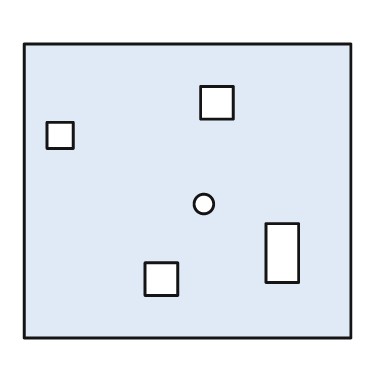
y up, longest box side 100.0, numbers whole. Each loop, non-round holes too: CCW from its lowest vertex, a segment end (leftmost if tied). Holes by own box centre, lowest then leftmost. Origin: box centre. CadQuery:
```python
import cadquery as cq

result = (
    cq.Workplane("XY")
    .moveTo(-50.0, -45.0)
    .lineTo(50.0, -45.0)
    .lineTo(50.0, 45.0)
    .lineTo(-50.0, 45.0)
    .close()
    .moveTo(-13.0, -32.0)
    .lineTo(-3.0, -32.0)
    .lineTo(-3.0, -22.0)
    .lineTo(-13.0, -22.0)
    .close()
    .moveTo(24.0, -28.0)
    .lineTo(34.0, -28.0)
    .lineTo(34.0, -10.0)
    .lineTo(24.0, -10.0)
    .close()
    .moveTo(5.0, -4.0)
    .circle(3.0)
    .moveTo(-43.0, 13.0)
    .lineTo(-35.0, 13.0)
    .lineTo(-35.0, 21.0)
    .lineTo(-43.0, 21.0)
    .close()
    .moveTo(4.0, 22.0)
    .lineTo(14.0, 22.0)
    .lineTo(14.0, 32.0)
    .lineTo(4.0, 32.0)
    .close()
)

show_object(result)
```